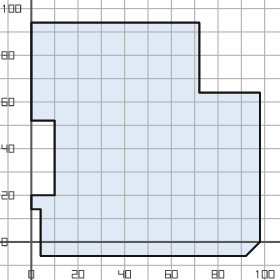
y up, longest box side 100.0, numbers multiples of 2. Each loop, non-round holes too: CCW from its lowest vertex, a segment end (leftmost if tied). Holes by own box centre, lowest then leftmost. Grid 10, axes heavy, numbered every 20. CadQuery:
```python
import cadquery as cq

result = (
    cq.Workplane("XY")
    .moveTo(4.0, -6.0)
    .lineTo(92.0, -6.0)
    .lineTo(98.0, 0.0)
    .lineTo(98.0, 64.0)
    .lineTo(72.0, 64.0)
    .lineTo(72.0, 94.0)
    .lineTo(0.0, 94.0)
    .lineTo(0.0, 52.0)
    .lineTo(10.0, 52.0)
    .lineTo(10.0, 20.0)
    .lineTo(0.0, 20.0)
    .lineTo(0.0, 14.0)
    .lineTo(4.0, 14.0)
    .close()
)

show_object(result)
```